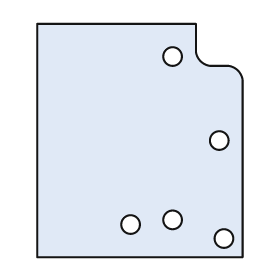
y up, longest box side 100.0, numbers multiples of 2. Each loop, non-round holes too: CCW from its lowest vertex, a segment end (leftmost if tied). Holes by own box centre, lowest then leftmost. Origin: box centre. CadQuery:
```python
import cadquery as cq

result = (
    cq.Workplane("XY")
    .moveTo(-44.0, -50.0)
    .lineTo(44.0, -50.0)
    .lineTo(44.0, 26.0)
    .threePointArc((42.0, 30.0), (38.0, 32.0))
    .lineTo(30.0, 32.0)
    .threePointArc((26.0, 34.0), (24.0, 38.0))
    .lineTo(24.0, 50.0)
    .lineTo(-44.0, 50.0)
    .close()
    .moveTo(36.0, -42.0)
    .circle(4.0)
    .moveTo(-4.0, -36.0)
    .circle(4.0)
    .moveTo(14.0, -34.0)
    .circle(4.0)
    .moveTo(34.0, 0.0)
    .circle(4.0)
    .moveTo(14.0, 36.0)
    .circle(4.0)
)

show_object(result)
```